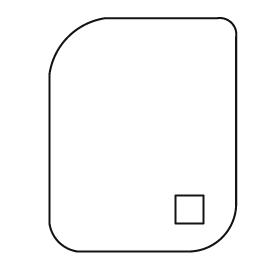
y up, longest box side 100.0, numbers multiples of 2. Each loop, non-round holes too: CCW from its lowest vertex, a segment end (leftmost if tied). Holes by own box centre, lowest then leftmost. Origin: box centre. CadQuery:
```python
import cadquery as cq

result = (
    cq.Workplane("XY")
    .moveTo(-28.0, -50.0)
    .lineTo(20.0, -50.0)
    .threePointArc((34.0, -44.0), (40.0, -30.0))
    .lineTo(40.0, 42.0)
    .threePointArc((38.0, 48.0), (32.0, 50.0))
    .lineTo(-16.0, 50.0)
    .threePointArc((-32.0, 42.0), (-40.0, 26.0))
    .lineTo(-40.0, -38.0)
    .threePointArc((-36.0, -46.0), (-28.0, -50.0))
    .close()
    .moveTo(14.0, -38.0)
    .lineTo(26.0, -38.0)
    .lineTo(26.0, -26.0)
    .lineTo(14.0, -26.0)
    .close()
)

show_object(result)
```